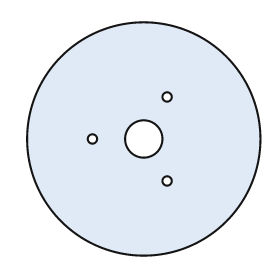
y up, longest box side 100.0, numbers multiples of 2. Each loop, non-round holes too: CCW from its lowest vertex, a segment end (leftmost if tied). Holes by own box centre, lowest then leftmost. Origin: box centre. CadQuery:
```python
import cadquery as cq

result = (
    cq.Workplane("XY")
    .moveTo(0.0, 0.0)
    .circle(50.0)
    .moveTo(10.0, -18.0)
    .circle(2.0)
    .moveTo(-22.0, 0.0)
    .circle(2.0)
    .moveTo(0.0, 0.0)
    .circle(8.0)
    .moveTo(10.0, 18.0)
    .circle(2.0)
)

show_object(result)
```